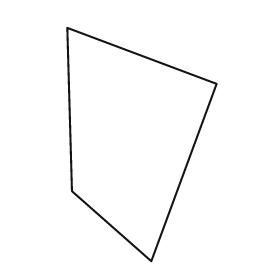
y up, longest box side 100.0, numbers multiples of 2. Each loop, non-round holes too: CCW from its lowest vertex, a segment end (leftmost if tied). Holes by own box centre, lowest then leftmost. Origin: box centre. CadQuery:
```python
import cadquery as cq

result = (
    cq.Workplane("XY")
    .moveTo(4.0, -50.0)
    .lineTo(32.0, 26.0)
    .lineTo(-32.0, 50.0)
    .lineTo(-30.0, -20.0)
    .close()
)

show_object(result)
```